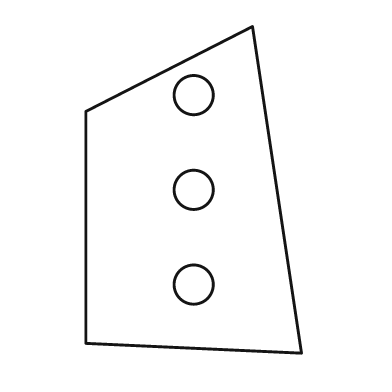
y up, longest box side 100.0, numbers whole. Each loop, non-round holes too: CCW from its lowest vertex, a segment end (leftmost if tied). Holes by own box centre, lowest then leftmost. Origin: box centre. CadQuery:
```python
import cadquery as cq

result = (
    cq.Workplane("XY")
    .moveTo(33.0, -50.0)
    .lineTo(18.0, 50.0)
    .lineTo(-33.0, 24.0)
    .lineTo(-33.0, -47.0)
    .close()
    .moveTo(0.0, -29.0)
    .circle(6.0)
    .moveTo(0.0, 0.0)
    .circle(6.0)
    .moveTo(0.0, 29.0)
    .circle(6.0)
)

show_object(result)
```